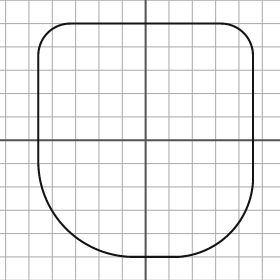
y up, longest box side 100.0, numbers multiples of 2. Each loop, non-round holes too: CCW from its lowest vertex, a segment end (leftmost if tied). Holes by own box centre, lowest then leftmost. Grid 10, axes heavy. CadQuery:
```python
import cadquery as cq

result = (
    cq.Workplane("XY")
    .moveTo(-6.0, -50.0)
    .lineTo(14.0, -50.0)
    .threePointArc((36.0, -40.0), (46.0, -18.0))
    .lineTo(46.0, 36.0)
    .threePointArc((42.0, 46.0), (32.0, 50.0))
    .lineTo(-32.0, 50.0)
    .threePointArc((-42.0, 46.0), (-46.0, 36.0))
    .lineTo(-46.0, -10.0)
    .threePointArc((-34.0, -38.0), (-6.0, -50.0))
    .close()
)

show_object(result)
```